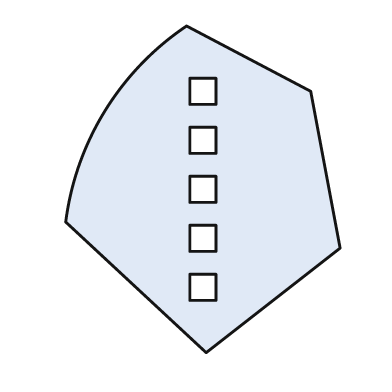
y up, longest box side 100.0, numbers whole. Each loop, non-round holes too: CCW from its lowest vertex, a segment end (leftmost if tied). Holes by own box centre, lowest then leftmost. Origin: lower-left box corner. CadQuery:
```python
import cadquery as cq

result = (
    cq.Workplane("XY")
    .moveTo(43.0, 0.0)
    .lineTo(84.0, 32.0)
    .lineTo(75.0, 80.0)
    .lineTo(37.0, 100.0)
    .threePointArc((12.0, 74.0), (0.0, 40.0))
    .close()
    .moveTo(38.0, 16.0)
    .lineTo(46.0, 16.0)
    .lineTo(46.0, 24.0)
    .lineTo(38.0, 24.0)
    .close()
    .moveTo(38.0, 31.0)
    .lineTo(46.0, 31.0)
    .lineTo(46.0, 39.0)
    .lineTo(38.0, 39.0)
    .close()
    .moveTo(38.0, 46.0)
    .lineTo(46.0, 46.0)
    .lineTo(46.0, 54.0)
    .lineTo(38.0, 54.0)
    .close()
    .moveTo(38.0, 61.0)
    .lineTo(46.0, 61.0)
    .lineTo(46.0, 69.0)
    .lineTo(38.0, 69.0)
    .close()
    .moveTo(38.0, 76.0)
    .lineTo(46.0, 76.0)
    .lineTo(46.0, 84.0)
    .lineTo(38.0, 84.0)
    .close()
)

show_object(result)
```